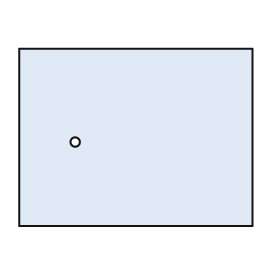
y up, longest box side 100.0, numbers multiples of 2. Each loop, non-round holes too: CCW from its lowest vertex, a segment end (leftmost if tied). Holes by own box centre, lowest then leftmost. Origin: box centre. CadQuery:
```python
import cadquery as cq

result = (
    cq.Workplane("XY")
    .moveTo(-50.0, -38.0)
    .lineTo(50.0, -38.0)
    .lineTo(50.0, 38.0)
    .lineTo(-50.0, 38.0)
    .close()
    .moveTo(-26.0, -2.0)
    .circle(2.0)
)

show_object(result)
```